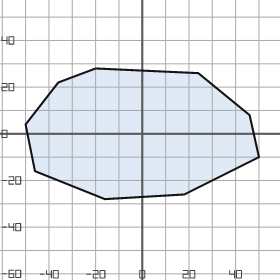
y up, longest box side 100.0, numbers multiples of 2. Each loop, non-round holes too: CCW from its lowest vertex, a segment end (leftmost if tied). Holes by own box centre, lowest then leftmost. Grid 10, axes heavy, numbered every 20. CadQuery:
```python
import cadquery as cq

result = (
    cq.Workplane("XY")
    .moveTo(-16.0, -28.0)
    .lineTo(18.0, -26.0)
    .lineTo(50.0, -10.0)
    .lineTo(46.0, 8.0)
    .lineTo(24.0, 26.0)
    .lineTo(-20.0, 28.0)
    .lineTo(-36.0, 22.0)
    .lineTo(-50.0, 4.0)
    .lineTo(-46.0, -16.0)
    .close()
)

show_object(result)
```